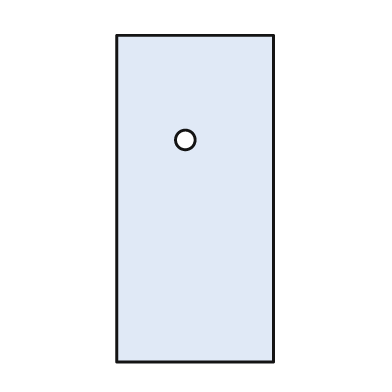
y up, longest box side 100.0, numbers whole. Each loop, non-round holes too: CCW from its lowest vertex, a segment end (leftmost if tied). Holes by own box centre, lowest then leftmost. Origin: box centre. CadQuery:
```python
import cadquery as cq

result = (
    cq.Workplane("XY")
    .moveTo(-24.0, -50.0)
    .lineTo(24.0, -50.0)
    .lineTo(24.0, 50.0)
    .lineTo(-24.0, 50.0)
    .close()
    .moveTo(-3.0, 18.0)
    .circle(3.0)
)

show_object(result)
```